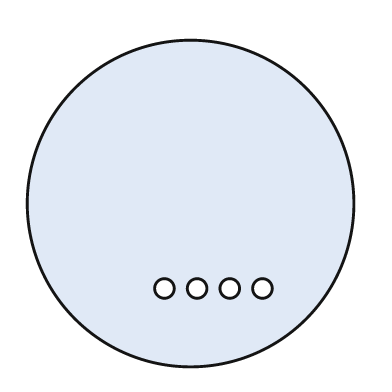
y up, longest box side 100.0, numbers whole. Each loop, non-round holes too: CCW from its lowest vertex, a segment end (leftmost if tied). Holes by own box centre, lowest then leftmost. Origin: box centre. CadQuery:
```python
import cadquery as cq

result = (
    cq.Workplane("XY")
    .moveTo(0.0, 0.0)
    .circle(50.0)
    .moveTo(-8.0, -26.0)
    .circle(3.0)
    .moveTo(2.0, -26.0)
    .circle(3.0)
    .moveTo(12.0, -26.0)
    .circle(3.0)
    .moveTo(22.0, -26.0)
    .circle(3.0)
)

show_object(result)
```